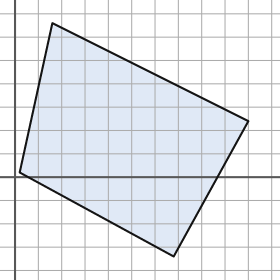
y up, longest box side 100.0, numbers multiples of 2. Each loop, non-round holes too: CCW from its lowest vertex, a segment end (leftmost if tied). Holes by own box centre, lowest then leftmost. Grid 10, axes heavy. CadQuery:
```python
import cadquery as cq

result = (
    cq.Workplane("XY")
    .moveTo(68.0, -34.0)
    .lineTo(100.0, 24.0)
    .lineTo(16.0, 66.0)
    .lineTo(2.0, 2.0)
    .close()
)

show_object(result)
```